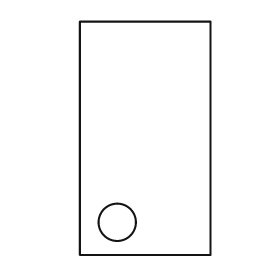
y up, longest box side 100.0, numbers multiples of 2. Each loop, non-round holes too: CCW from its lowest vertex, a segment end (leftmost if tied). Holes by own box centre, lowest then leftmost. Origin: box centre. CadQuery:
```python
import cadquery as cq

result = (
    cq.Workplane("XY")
    .moveTo(-28.0, -50.0)
    .lineTo(28.0, -50.0)
    .lineTo(28.0, 50.0)
    .lineTo(-28.0, 50.0)
    .close()
    .moveTo(-12.0, -36.0)
    .circle(8.0)
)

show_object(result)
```